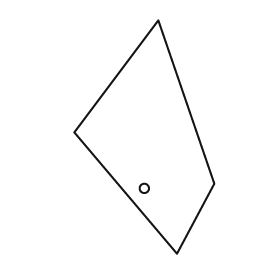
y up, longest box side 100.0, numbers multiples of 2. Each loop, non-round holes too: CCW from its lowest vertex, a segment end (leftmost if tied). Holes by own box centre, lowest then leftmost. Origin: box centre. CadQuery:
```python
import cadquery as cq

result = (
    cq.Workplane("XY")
    .moveTo(14.0, -50.0)
    .lineTo(30.0, -20.0)
    .lineTo(6.0, 50.0)
    .lineTo(-30.0, 2.0)
    .close()
    .moveTo(0.0, -22.0)
    .circle(2.0)
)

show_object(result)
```